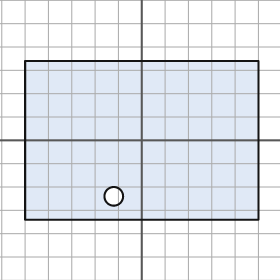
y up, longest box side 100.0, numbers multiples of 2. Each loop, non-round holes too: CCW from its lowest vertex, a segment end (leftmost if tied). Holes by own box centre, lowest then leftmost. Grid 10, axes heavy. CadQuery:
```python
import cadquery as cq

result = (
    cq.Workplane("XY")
    .moveTo(-50.0, -34.0)
    .lineTo(50.0, -34.0)
    .lineTo(50.0, 34.0)
    .lineTo(-50.0, 34.0)
    .close()
    .moveTo(-12.0, -24.0)
    .circle(4.0)
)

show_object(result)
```